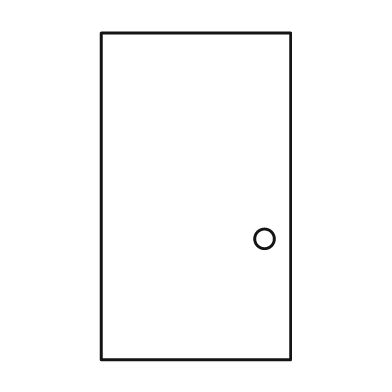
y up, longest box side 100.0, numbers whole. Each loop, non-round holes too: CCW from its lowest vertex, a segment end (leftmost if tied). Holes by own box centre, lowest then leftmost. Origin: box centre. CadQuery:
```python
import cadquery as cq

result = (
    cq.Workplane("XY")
    .moveTo(-29.0, -50.0)
    .lineTo(29.0, -50.0)
    .lineTo(29.0, 50.0)
    .lineTo(-29.0, 50.0)
    .close()
    .moveTo(21.0, -13.0)
    .circle(3.0)
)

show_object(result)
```